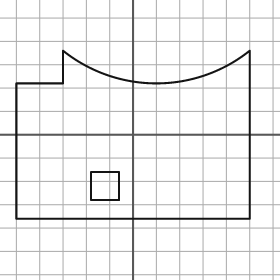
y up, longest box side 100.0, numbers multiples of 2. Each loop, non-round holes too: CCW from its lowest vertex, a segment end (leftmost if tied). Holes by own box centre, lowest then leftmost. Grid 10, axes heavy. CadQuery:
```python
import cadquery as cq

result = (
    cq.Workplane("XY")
    .moveTo(-50.0, -36.0)
    .lineTo(50.0, -36.0)
    .lineTo(50.0, 36.0)
    .threePointArc((10.0, 22.0), (-30.0, 36.0))
    .lineTo(-30.0, 22.0)
    .lineTo(-50.0, 22.0)
    .close()
    .moveTo(-18.0, -28.0)
    .lineTo(-6.0, -28.0)
    .lineTo(-6.0, -16.0)
    .lineTo(-18.0, -16.0)
    .close()
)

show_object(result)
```